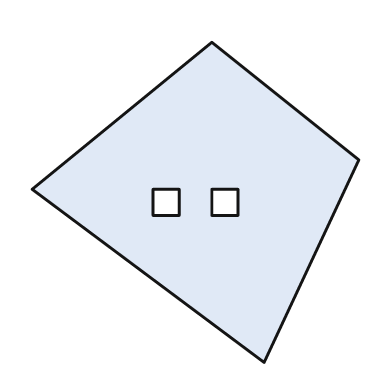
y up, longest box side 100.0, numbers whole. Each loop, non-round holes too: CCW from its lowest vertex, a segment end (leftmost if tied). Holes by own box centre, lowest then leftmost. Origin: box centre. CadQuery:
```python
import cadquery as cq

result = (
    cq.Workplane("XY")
    .moveTo(21.0, -49.0)
    .lineTo(50.0, 13.0)
    .lineTo(5.0, 49.0)
    .lineTo(-50.0, 4.0)
    .close()
    .moveTo(-13.0, -4.0)
    .lineTo(-5.0, -4.0)
    .lineTo(-5.0, 4.0)
    .lineTo(-13.0, 4.0)
    .close()
    .moveTo(5.0, -4.0)
    .lineTo(13.0, -4.0)
    .lineTo(13.0, 4.0)
    .lineTo(5.0, 4.0)
    .close()
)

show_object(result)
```